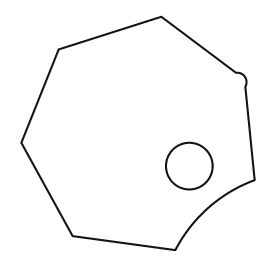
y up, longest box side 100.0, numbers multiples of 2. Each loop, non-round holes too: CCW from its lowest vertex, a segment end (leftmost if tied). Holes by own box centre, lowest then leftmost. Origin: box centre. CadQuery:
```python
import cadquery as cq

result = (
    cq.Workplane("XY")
    .moveTo(16.0, -50.0)
    .threePointArc((30.0, -32.0), (50.0, -20.0))
    .lineTo(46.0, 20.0)
    .threePointArc((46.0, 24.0), (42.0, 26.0))
    .lineTo(10.0, 50.0)
    .lineTo(-34.0, 36.0)
    .lineTo(-50.0, -4.0)
    .lineTo(-28.0, -44.0)
    .close()
    .moveTo(22.0, -14.0)
    .circle(10.0)
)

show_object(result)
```